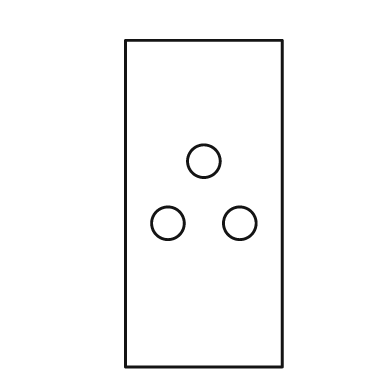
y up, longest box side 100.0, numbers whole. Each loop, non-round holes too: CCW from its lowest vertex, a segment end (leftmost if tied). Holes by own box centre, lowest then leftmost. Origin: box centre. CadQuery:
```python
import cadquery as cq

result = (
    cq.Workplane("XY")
    .moveTo(-24.0, -50.0)
    .lineTo(24.0, -50.0)
    .lineTo(24.0, 50.0)
    .lineTo(-24.0, 50.0)
    .close()
    .moveTo(-11.0, -6.0)
    .circle(5.0)
    .moveTo(11.0, -6.0)
    .circle(5.0)
    .moveTo(0.0, 13.0)
    .circle(5.0)
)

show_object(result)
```